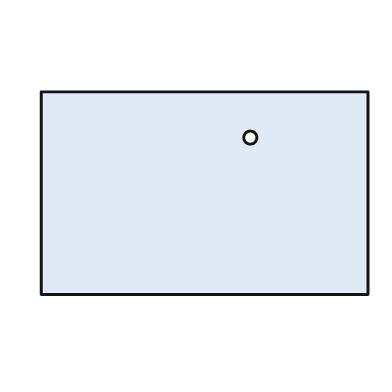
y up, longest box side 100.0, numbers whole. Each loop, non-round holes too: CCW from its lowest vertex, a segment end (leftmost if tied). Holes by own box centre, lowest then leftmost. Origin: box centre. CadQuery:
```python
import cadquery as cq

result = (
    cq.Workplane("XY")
    .moveTo(-50.0, -31.0)
    .lineTo(50.0, -31.0)
    .lineTo(50.0, 31.0)
    .lineTo(-50.0, 31.0)
    .close()
    .moveTo(14.0, 17.0)
    .circle(2.0)
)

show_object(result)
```